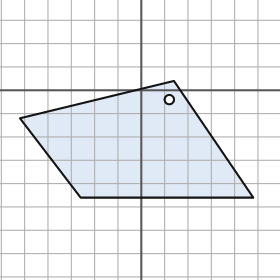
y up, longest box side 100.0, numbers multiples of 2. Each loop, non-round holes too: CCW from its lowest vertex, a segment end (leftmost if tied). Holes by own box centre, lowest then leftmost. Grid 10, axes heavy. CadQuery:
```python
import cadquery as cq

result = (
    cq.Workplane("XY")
    .moveTo(-26.0, -46.0)
    .lineTo(48.0, -46.0)
    .lineTo(14.0, 4.0)
    .lineTo(-52.0, -12.0)
    .close()
    .moveTo(12.0, -4.0)
    .circle(2.0)
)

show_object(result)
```